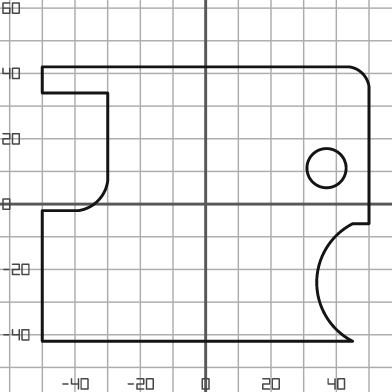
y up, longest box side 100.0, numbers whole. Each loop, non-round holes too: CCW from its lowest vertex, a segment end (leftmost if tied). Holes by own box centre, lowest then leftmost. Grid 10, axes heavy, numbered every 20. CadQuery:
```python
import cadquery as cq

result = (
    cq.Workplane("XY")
    .moveTo(-50.0, -42.0)
    .lineTo(45.0, -42.0)
    .threePointArc((34.0, -24.0), (45.0, -6.0))
    .lineTo(50.0, -6.0)
    .lineTo(50.0, 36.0)
    .threePointArc((48.0, 40.0), (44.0, 42.0))
    .lineTo(-50.0, 42.0)
    .lineTo(-50.0, 34.0)
    .lineTo(-30.0, 34.0)
    .lineTo(-30.0, 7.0)
    .threePointArc((-33.0, 1.0), (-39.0, -2.0))
    .lineTo(-50.0, -2.0)
    .close()
    .moveTo(37.0, 11.0)
    .circle(6.0)
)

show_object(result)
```